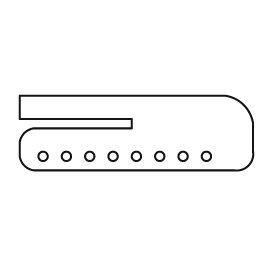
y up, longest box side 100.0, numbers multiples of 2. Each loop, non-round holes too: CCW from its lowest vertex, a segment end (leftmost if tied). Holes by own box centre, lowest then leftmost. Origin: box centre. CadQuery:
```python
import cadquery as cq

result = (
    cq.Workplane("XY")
    .moveTo(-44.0, -16.0)
    .lineTo(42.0, -16.0)
    .threePointArc((48.0, -14.0), (50.0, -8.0))
    .lineTo(50.0, 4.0)
    .threePointArc((46.0, 12.0), (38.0, 16.0))
    .lineTo(-50.0, 16.0)
    .lineTo(-50.0, 6.0)
    .lineTo(-2.0, 6.0)
    .lineTo(-2.0, 2.0)
    .lineTo(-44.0, 2.0)
    .threePointArc((-48.0, 0.0), (-50.0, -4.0))
    .lineTo(-50.0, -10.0)
    .threePointArc((-48.0, -14.0), (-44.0, -16.0))
    .close()
    .moveTo(-40.0, -10.0)
    .circle(2.0)
    .moveTo(-30.0, -10.0)
    .circle(2.0)
    .moveTo(-20.0, -10.0)
    .circle(2.0)
    .moveTo(-10.0, -10.0)
    .circle(2.0)
    .moveTo(0.0, -10.0)
    .circle(2.0)
    .moveTo(10.0, -10.0)
    .circle(2.0)
    .moveTo(20.0, -10.0)
    .circle(2.0)
    .moveTo(30.0, -10.0)
    .circle(2.0)
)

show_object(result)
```